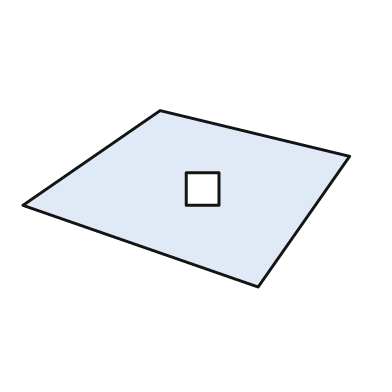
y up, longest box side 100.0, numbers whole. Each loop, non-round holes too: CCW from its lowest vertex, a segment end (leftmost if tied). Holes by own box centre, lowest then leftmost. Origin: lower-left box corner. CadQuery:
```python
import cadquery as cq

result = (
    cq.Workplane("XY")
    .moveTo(72.0, 0.0)
    .lineTo(100.0, 40.0)
    .lineTo(42.0, 54.0)
    .lineTo(0.0, 25.0)
    .close()
    .moveTo(50.0, 25.0)
    .lineTo(60.0, 25.0)
    .lineTo(60.0, 35.0)
    .lineTo(50.0, 35.0)
    .close()
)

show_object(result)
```